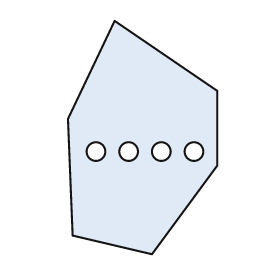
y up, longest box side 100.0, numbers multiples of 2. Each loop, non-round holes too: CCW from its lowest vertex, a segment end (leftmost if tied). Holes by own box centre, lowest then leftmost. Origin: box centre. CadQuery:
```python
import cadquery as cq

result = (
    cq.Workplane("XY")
    .moveTo(4.0, -50.0)
    .lineTo(32.0, -12.0)
    .lineTo(32.0, 20.0)
    .lineTo(-12.0, 50.0)
    .lineTo(-32.0, 8.0)
    .lineTo(-30.0, -42.0)
    .close()
    .moveTo(-20.0, -6.0)
    .circle(4.0)
    .moveTo(-6.0, -6.0)
    .circle(4.0)
    .moveTo(8.0, -6.0)
    .circle(4.0)
    .moveTo(22.0, -6.0)
    .circle(4.0)
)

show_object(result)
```